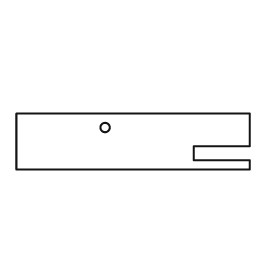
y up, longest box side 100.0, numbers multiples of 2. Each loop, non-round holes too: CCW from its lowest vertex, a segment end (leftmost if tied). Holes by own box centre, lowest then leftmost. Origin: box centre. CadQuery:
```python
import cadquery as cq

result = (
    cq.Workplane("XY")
    .moveTo(-50.0, -12.0)
    .lineTo(50.0, -12.0)
    .lineTo(50.0, -8.0)
    .lineTo(26.0, -8.0)
    .lineTo(26.0, -2.0)
    .lineTo(50.0, -2.0)
    .lineTo(50.0, 12.0)
    .lineTo(-50.0, 12.0)
    .close()
    .moveTo(-12.0, 6.0)
    .circle(2.0)
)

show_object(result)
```